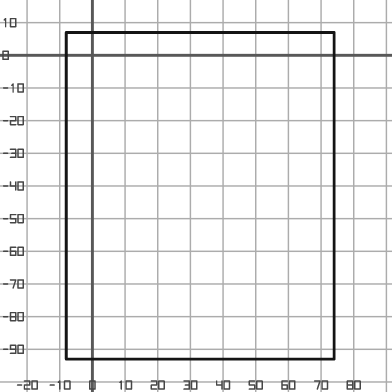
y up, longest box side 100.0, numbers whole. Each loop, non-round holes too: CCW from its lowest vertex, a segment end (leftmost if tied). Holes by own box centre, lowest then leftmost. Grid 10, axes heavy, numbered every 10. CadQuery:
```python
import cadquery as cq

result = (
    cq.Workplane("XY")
    .moveTo(-8.0, -93.0)
    .lineTo(74.0, -93.0)
    .lineTo(74.0, 7.0)
    .lineTo(-8.0, 7.0)
    .close()
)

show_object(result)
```